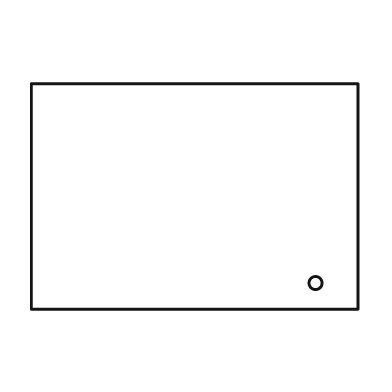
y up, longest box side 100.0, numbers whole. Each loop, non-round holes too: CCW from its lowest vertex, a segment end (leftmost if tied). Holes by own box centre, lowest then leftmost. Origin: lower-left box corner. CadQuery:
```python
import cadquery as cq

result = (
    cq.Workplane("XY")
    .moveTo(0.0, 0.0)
    .lineTo(100.0, 0.0)
    .lineTo(100.0, 69.0)
    .lineTo(0.0, 69.0)
    .close()
    .moveTo(87.0, 8.0)
    .circle(2.0)
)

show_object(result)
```